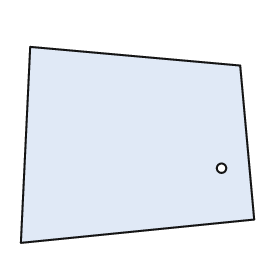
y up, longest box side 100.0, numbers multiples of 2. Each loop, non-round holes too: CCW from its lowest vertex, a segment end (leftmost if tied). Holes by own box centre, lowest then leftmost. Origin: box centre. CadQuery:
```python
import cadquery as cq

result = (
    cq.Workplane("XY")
    .moveTo(-50.0, -42.0)
    .lineTo(50.0, -32.0)
    .lineTo(44.0, 34.0)
    .lineTo(-46.0, 42.0)
    .close()
    .moveTo(36.0, -10.0)
    .circle(2.0)
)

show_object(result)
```